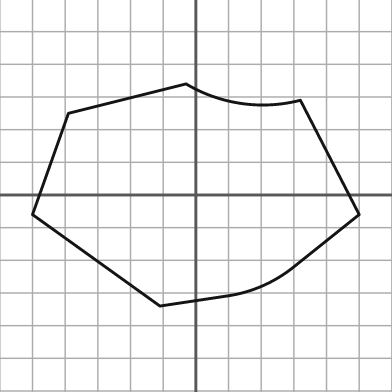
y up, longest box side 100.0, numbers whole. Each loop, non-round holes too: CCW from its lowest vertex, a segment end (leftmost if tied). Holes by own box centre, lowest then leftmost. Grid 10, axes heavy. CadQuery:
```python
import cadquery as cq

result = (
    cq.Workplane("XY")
    .moveTo(-11.0, -34.0)
    .lineTo(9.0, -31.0)
    .threePointArc((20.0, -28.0), (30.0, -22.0))
    .lineTo(50.0, -6.0)
    .lineTo(32.0, 29.0)
    .threePointArc((14.0, 28.0), (-3.0, 34.0))
    .lineTo(-39.0, 25.0)
    .lineTo(-50.0, -6.0)
    .close()
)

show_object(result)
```